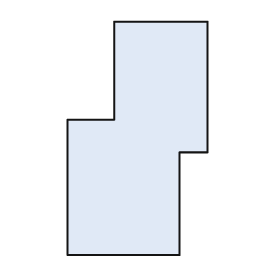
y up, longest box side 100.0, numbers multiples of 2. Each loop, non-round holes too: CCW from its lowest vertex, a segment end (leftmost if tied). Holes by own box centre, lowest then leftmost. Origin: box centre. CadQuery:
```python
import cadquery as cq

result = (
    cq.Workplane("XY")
    .moveTo(-30.0, -50.0)
    .lineTo(18.0, -50.0)
    .lineTo(18.0, -6.0)
    .lineTo(30.0, -6.0)
    .lineTo(30.0, 50.0)
    .lineTo(-10.0, 50.0)
    .lineTo(-10.0, 8.0)
    .lineTo(-30.0, 8.0)
    .close()
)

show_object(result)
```